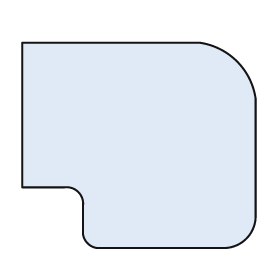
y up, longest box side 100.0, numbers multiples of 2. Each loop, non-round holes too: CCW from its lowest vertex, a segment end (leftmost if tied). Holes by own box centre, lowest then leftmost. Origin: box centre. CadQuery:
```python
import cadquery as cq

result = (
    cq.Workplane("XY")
    .moveTo(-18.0, -44.0)
    .lineTo(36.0, -44.0)
    .threePointArc((46.0, -40.0), (50.0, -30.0))
    .lineTo(50.0, 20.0)
    .threePointArc((42.0, 36.0), (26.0, 44.0))
    .lineTo(-50.0, 44.0)
    .lineTo(-50.0, -18.0)
    .lineTo(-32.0, -18.0)
    .threePointArc((-26.0, -20.0), (-24.0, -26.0))
    .lineTo(-24.0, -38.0)
    .threePointArc((-22.0, -42.0), (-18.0, -44.0))
    .close()
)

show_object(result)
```